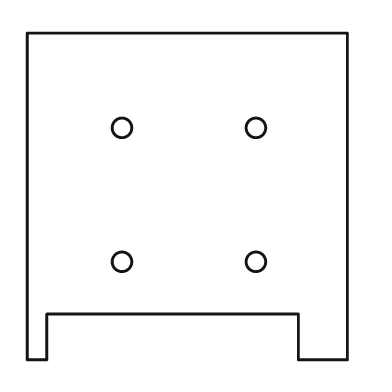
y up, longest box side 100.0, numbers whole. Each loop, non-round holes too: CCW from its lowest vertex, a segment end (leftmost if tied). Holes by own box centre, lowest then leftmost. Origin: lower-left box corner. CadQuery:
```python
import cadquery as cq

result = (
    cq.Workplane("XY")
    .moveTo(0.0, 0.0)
    .lineTo(6.0, 0.0)
    .lineTo(6.0, 14.0)
    .lineTo(83.0, 14.0)
    .lineTo(83.0, 0.0)
    .lineTo(98.0, 0.0)
    .lineTo(98.0, 100.0)
    .lineTo(0.0, 100.0)
    .close()
    .moveTo(29.0, 30.0)
    .circle(3.0)
    .moveTo(70.0, 30.0)
    .circle(3.0)
    .moveTo(29.0, 71.0)
    .circle(3.0)
    .moveTo(70.0, 71.0)
    .circle(3.0)
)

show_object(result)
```